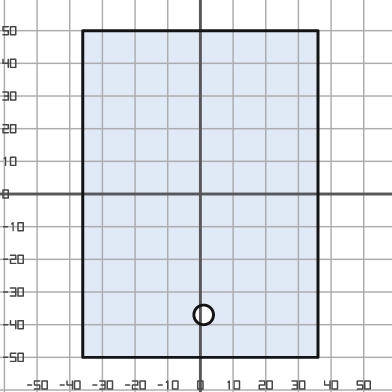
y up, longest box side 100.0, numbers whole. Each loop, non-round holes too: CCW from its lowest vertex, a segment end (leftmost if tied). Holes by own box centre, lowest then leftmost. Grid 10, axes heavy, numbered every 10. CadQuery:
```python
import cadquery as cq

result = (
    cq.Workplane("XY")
    .moveTo(-36.0, -50.0)
    .lineTo(36.0, -50.0)
    .lineTo(36.0, 50.0)
    .lineTo(-36.0, 50.0)
    .close()
    .moveTo(1.0, -37.0)
    .circle(3.0)
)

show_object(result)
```